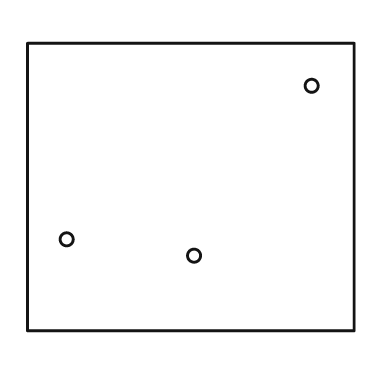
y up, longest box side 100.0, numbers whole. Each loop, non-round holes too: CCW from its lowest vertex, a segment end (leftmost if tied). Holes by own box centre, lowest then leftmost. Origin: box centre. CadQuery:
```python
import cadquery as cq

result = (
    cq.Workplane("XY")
    .moveTo(-50.0, -44.0)
    .lineTo(50.0, -44.0)
    .lineTo(50.0, 44.0)
    .lineTo(-50.0, 44.0)
    .close()
    .moveTo(1.0, -21.0)
    .circle(2.0)
    .moveTo(-38.0, -16.0)
    .circle(2.0)
    .moveTo(37.0, 31.0)
    .circle(2.0)
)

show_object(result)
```